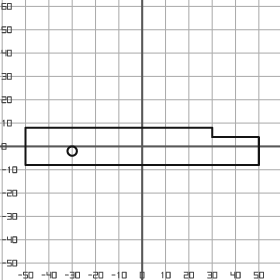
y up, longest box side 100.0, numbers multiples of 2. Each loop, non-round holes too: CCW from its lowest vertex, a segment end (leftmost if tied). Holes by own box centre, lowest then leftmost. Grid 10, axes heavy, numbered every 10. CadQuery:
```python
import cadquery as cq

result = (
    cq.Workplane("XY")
    .moveTo(-50.0, -8.0)
    .lineTo(50.0, -8.0)
    .lineTo(50.0, 4.0)
    .lineTo(30.0, 4.0)
    .lineTo(30.0, 8.0)
    .lineTo(-50.0, 8.0)
    .close()
    .moveTo(-30.0, -2.0)
    .circle(2.0)
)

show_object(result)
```